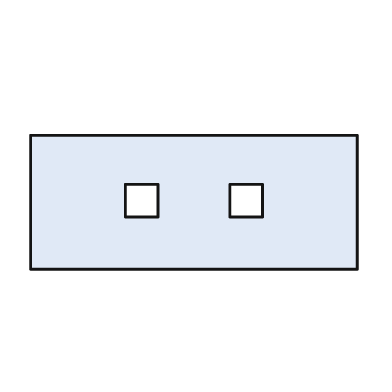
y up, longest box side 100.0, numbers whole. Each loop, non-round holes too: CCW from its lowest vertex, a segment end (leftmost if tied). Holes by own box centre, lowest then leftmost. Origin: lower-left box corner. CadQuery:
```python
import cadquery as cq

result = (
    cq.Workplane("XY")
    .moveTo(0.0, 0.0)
    .lineTo(100.0, 0.0)
    .lineTo(100.0, 41.0)
    .lineTo(0.0, 41.0)
    .close()
    .moveTo(29.0, 16.0)
    .lineTo(39.0, 16.0)
    .lineTo(39.0, 26.0)
    .lineTo(29.0, 26.0)
    .close()
    .moveTo(61.0, 16.0)
    .lineTo(71.0, 16.0)
    .lineTo(71.0, 26.0)
    .lineTo(61.0, 26.0)
    .close()
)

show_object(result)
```